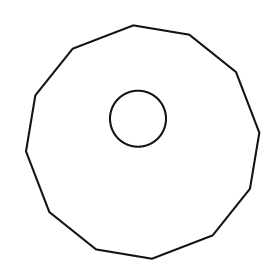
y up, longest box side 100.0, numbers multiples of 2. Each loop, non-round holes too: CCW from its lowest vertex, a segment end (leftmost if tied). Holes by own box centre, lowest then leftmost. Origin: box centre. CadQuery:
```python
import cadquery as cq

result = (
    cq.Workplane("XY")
    .moveTo(4.0, -50.0)
    .lineTo(30.0, -40.0)
    .lineTo(46.0, -20.0)
    .lineTo(50.0, 4.0)
    .lineTo(40.0, 30.0)
    .lineTo(20.0, 46.0)
    .lineTo(-4.0, 50.0)
    .lineTo(-30.0, 40.0)
    .lineTo(-46.0, 20.0)
    .lineTo(-50.0, -4.0)
    .lineTo(-40.0, -30.0)
    .lineTo(-20.0, -46.0)
    .close()
    .moveTo(-2.0, 10.0)
    .circle(12.0)
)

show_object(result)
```